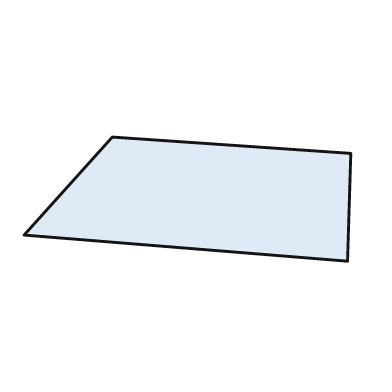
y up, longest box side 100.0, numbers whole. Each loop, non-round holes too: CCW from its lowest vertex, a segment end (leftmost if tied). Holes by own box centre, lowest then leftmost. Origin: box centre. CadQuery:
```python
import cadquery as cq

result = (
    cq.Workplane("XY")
    .moveTo(49.0, -19.0)
    .lineTo(50.0, 14.0)
    .lineTo(-23.0, 19.0)
    .lineTo(-50.0, -11.0)
    .close()
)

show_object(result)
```